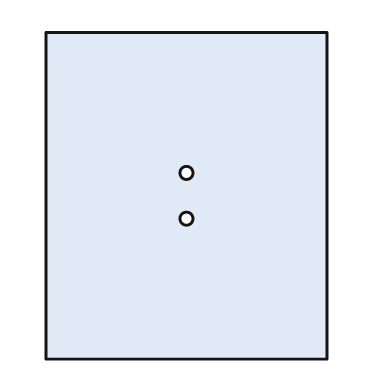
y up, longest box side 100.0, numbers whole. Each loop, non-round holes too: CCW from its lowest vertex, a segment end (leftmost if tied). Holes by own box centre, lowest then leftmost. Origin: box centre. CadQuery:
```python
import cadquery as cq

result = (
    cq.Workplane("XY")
    .moveTo(-43.0, -50.0)
    .lineTo(43.0, -50.0)
    .lineTo(43.0, 50.0)
    .lineTo(-43.0, 50.0)
    .close()
    .moveTo(0.0, -7.0)
    .circle(2.0)
    .moveTo(0.0, 7.0)
    .circle(2.0)
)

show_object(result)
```